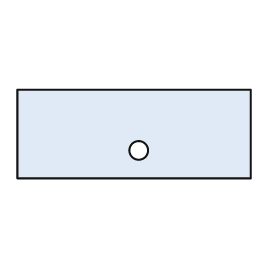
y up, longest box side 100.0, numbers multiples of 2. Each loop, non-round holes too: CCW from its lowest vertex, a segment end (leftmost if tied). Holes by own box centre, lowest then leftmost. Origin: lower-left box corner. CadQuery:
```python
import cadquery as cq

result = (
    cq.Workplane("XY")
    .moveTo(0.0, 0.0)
    .lineTo(100.0, 0.0)
    .lineTo(100.0, 38.0)
    .lineTo(0.0, 38.0)
    .close()
    .moveTo(52.0, 12.0)
    .circle(4.0)
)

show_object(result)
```